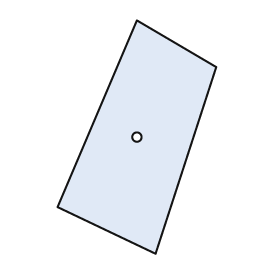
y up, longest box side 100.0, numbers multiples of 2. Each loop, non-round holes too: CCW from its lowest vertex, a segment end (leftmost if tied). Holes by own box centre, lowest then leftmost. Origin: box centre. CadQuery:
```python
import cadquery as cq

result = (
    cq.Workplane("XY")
    .moveTo(8.0, -50.0)
    .lineTo(34.0, 30.0)
    .lineTo(0.0, 50.0)
    .lineTo(-34.0, -30.0)
    .close()
    .moveTo(0.0, 0.0)
    .circle(2.0)
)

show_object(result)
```